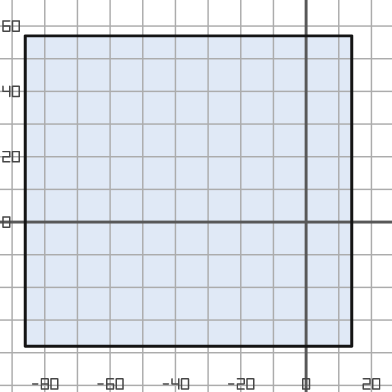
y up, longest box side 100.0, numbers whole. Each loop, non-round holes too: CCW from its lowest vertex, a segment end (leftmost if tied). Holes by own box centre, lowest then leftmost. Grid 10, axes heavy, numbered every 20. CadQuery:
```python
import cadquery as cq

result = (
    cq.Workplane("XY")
    .moveTo(-86.0, -38.0)
    .lineTo(14.0, -38.0)
    .lineTo(14.0, 57.0)
    .lineTo(-86.0, 57.0)
    .close()
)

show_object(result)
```